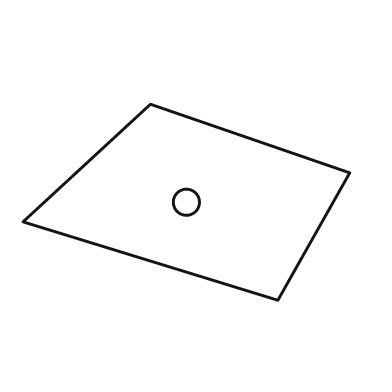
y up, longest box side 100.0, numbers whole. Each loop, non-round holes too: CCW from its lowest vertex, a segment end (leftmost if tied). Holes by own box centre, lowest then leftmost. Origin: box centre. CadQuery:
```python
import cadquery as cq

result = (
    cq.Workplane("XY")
    .moveTo(28.0, -30.0)
    .lineTo(50.0, 9.0)
    .lineTo(-11.0, 30.0)
    .lineTo(-50.0, -6.0)
    .close()
    .moveTo(0.0, 0.0)
    .circle(4.0)
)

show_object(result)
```